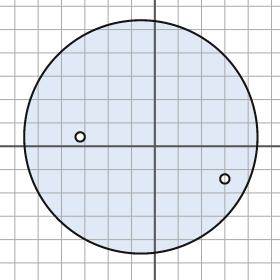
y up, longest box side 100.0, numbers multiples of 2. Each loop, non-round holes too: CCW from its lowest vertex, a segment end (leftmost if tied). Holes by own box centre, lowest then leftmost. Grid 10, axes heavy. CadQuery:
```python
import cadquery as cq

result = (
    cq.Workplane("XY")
    .moveTo(-6.0, 4.0)
    .circle(50.0)
    .moveTo(30.0, -14.0)
    .circle(2.0)
    .moveTo(-32.0, 4.0)
    .circle(2.0)
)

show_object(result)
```